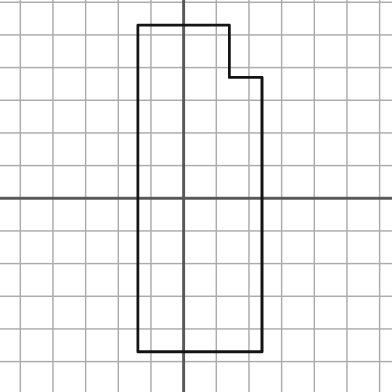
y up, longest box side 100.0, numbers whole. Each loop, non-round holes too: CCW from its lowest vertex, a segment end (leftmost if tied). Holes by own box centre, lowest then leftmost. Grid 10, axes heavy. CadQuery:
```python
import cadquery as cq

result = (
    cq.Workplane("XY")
    .moveTo(-14.0, -47.0)
    .lineTo(24.0, -47.0)
    .lineTo(24.0, 37.0)
    .lineTo(14.0, 37.0)
    .lineTo(14.0, 53.0)
    .lineTo(-14.0, 53.0)
    .close()
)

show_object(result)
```